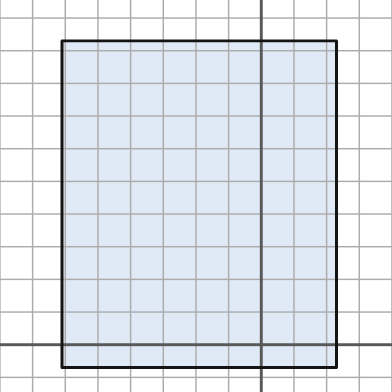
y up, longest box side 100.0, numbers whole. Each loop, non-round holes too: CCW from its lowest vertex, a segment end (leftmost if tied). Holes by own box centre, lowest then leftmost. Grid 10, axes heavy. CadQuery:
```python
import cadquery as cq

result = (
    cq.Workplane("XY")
    .moveTo(-61.0, -7.0)
    .lineTo(23.0, -7.0)
    .lineTo(23.0, 93.0)
    .lineTo(-61.0, 93.0)
    .close()
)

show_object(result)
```